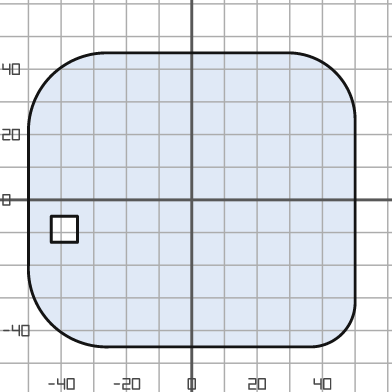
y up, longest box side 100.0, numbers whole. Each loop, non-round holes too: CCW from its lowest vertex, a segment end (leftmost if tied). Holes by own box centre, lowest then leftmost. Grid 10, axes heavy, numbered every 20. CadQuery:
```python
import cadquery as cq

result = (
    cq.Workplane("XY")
    .moveTo(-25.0, -45.0)
    .lineTo(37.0, -45.0)
    .threePointArc((46.0, -41.0), (50.0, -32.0))
    .lineTo(50.0, 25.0)
    .threePointArc((44.0, 39.0), (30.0, 45.0))
    .lineTo(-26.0, 45.0)
    .threePointArc((-43.0, 38.0), (-50.0, 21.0))
    .lineTo(-50.0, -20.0)
    .threePointArc((-43.0, -38.0), (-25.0, -45.0))
    .close()
    .moveTo(-43.0, -13.0)
    .lineTo(-35.0, -13.0)
    .lineTo(-35.0, -5.0)
    .lineTo(-43.0, -5.0)
    .close()
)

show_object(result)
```